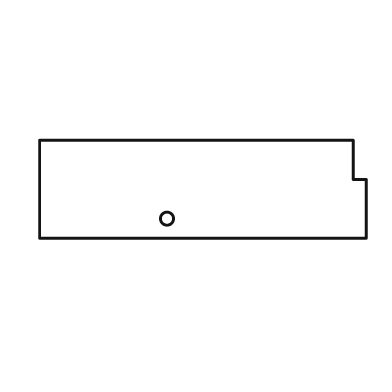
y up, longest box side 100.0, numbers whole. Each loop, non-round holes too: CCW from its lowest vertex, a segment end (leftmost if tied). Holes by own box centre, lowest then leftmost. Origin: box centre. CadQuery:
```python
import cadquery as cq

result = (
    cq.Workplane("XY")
    .moveTo(-50.0, -15.0)
    .lineTo(50.0, -15.0)
    .lineTo(50.0, 3.0)
    .lineTo(46.0, 3.0)
    .lineTo(46.0, 15.0)
    .lineTo(-50.0, 15.0)
    .close()
    .moveTo(-11.0, -9.0)
    .circle(2.0)
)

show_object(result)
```